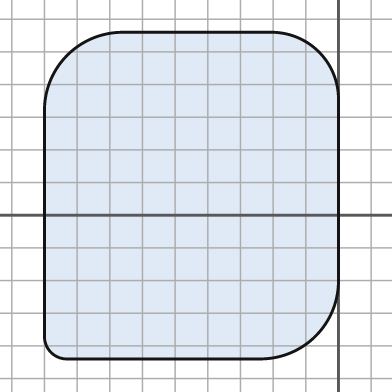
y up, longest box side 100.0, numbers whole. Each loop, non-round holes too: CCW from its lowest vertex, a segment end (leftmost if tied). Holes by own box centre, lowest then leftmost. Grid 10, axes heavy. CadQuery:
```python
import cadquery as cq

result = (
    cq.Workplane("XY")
    .moveTo(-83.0, -44.0)
    .lineTo(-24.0, -44.0)
    .threePointArc((-7.0, -37.0), (0.0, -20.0))
    .lineTo(0.0, 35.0)
    .threePointArc((-6.0, 50.0), (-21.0, 56.0))
    .lineTo(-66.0, 56.0)
    .threePointArc((-83.0, 49.0), (-90.0, 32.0))
    .lineTo(-90.0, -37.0)
    .threePointArc((-88.0, -42.0), (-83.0, -44.0))
    .close()
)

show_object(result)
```